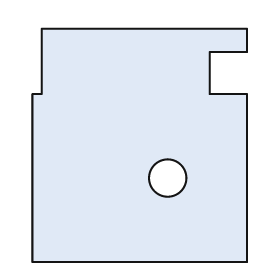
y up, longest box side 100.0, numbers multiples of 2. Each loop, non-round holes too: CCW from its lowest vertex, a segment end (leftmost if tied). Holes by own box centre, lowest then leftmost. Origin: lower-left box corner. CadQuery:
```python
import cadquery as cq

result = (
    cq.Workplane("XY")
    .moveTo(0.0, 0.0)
    .lineTo(92.0, 0.0)
    .lineTo(92.0, 72.0)
    .lineTo(76.0, 72.0)
    .lineTo(76.0, 90.0)
    .lineTo(92.0, 90.0)
    .lineTo(92.0, 100.0)
    .lineTo(4.0, 100.0)
    .lineTo(4.0, 72.0)
    .lineTo(0.0, 72.0)
    .close()
    .moveTo(58.0, 36.0)
    .circle(8.0)
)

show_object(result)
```